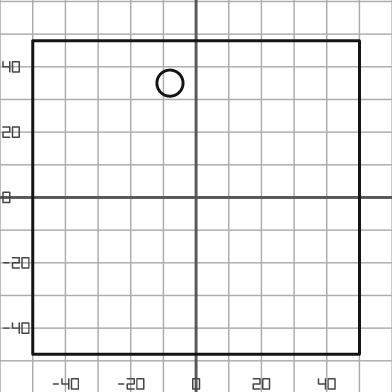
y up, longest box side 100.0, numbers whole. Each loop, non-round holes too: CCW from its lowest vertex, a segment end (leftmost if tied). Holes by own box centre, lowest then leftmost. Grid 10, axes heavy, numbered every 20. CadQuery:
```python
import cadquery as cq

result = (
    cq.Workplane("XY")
    .moveTo(-50.0, -48.0)
    .lineTo(50.0, -48.0)
    .lineTo(50.0, 48.0)
    .lineTo(-50.0, 48.0)
    .close()
    .moveTo(-8.0, 35.0)
    .circle(4.0)
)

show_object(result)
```